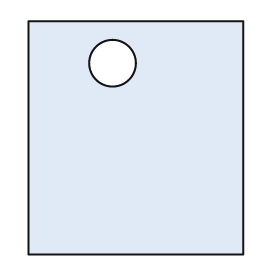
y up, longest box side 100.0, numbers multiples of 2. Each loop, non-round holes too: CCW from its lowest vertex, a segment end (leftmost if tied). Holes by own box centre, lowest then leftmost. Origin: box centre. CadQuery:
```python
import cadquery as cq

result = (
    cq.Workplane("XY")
    .moveTo(-46.0, -50.0)
    .lineTo(46.0, -50.0)
    .lineTo(46.0, 50.0)
    .lineTo(-46.0, 50.0)
    .close()
    .moveTo(-10.0, 32.0)
    .circle(10.0)
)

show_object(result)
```